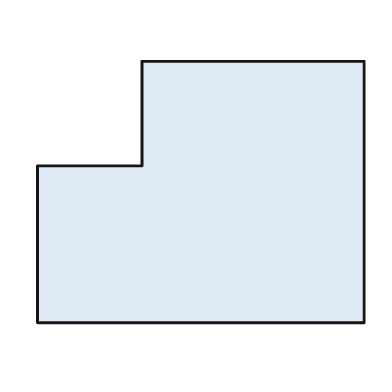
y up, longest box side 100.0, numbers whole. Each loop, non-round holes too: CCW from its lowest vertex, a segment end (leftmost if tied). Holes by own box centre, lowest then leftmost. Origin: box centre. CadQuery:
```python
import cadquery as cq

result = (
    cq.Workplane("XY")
    .moveTo(-50.0, -40.0)
    .lineTo(50.0, -40.0)
    .lineTo(50.0, 40.0)
    .lineTo(-18.0, 40.0)
    .lineTo(-18.0, 8.0)
    .lineTo(-50.0, 8.0)
    .close()
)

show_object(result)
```